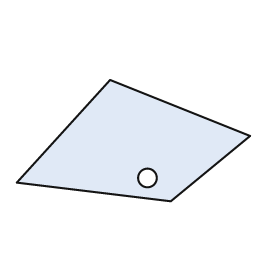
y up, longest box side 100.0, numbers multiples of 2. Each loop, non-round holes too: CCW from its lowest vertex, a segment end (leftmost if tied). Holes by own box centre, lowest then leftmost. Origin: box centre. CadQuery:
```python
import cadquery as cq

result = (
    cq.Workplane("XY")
    .moveTo(16.0, -26.0)
    .lineTo(50.0, 2.0)
    .lineTo(-10.0, 26.0)
    .lineTo(-50.0, -18.0)
    .close()
    .moveTo(6.0, -16.0)
    .circle(4.0)
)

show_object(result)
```